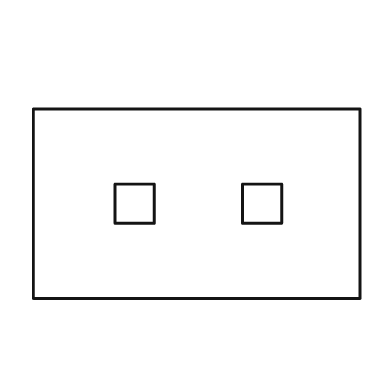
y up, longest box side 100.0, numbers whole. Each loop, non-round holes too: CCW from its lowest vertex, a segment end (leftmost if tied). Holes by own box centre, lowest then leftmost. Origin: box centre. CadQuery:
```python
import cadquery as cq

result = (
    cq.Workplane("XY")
    .moveTo(-50.0, -29.0)
    .lineTo(50.0, -29.0)
    .lineTo(50.0, 29.0)
    .lineTo(-50.0, 29.0)
    .close()
    .moveTo(-25.0, -6.0)
    .lineTo(-13.0, -6.0)
    .lineTo(-13.0, 6.0)
    .lineTo(-25.0, 6.0)
    .close()
    .moveTo(14.0, -6.0)
    .lineTo(26.0, -6.0)
    .lineTo(26.0, 6.0)
    .lineTo(14.0, 6.0)
    .close()
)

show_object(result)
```